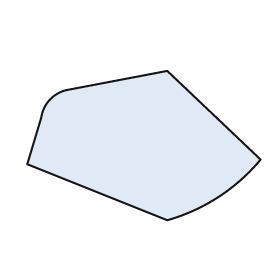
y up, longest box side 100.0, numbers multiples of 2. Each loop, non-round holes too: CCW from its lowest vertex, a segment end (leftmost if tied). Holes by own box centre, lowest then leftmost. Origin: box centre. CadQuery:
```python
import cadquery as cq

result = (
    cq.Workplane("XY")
    .moveTo(10.0, -32.0)
    .threePointArc((32.0, -22.0), (50.0, -6.0))
    .lineTo(10.0, 32.0)
    .lineTo(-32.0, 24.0)
    .threePointArc((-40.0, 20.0), (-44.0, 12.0))
    .lineTo(-50.0, -8.0)
    .close()
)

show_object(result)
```